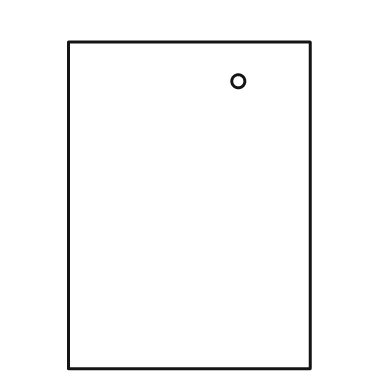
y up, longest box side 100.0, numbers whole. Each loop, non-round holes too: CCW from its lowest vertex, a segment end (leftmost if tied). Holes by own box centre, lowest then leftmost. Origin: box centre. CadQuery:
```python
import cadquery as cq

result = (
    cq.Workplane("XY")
    .moveTo(-37.0, -50.0)
    .lineTo(37.0, -50.0)
    .lineTo(37.0, 50.0)
    .lineTo(-37.0, 50.0)
    .close()
    .moveTo(15.0, 38.0)
    .circle(2.0)
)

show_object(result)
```